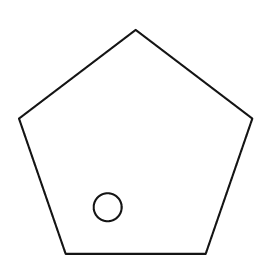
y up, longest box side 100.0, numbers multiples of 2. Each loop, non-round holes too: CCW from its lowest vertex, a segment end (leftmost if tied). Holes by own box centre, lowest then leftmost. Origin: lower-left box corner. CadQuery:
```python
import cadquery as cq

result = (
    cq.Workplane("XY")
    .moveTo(20.0, 0.0)
    .lineTo(80.0, 0.0)
    .lineTo(100.0, 58.0)
    .lineTo(50.0, 96.0)
    .lineTo(0.0, 58.0)
    .close()
    .moveTo(38.0, 20.0)
    .circle(6.0)
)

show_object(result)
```